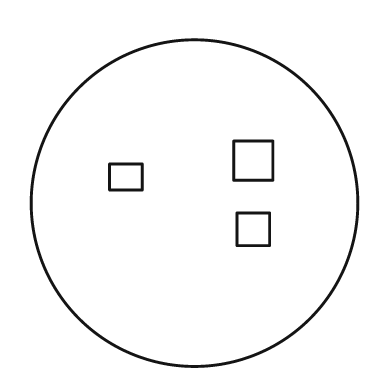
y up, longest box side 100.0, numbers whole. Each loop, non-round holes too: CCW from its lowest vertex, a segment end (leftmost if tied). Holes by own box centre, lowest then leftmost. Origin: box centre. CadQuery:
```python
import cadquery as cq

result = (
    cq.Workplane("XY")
    .moveTo(0.0, 0.0)
    .circle(50.0)
    .moveTo(13.0, -13.0)
    .lineTo(23.0, -13.0)
    .lineTo(23.0, -3.0)
    .lineTo(13.0, -3.0)
    .close()
    .moveTo(-26.0, 4.0)
    .lineTo(-16.0, 4.0)
    .lineTo(-16.0, 12.0)
    .lineTo(-26.0, 12.0)
    .close()
    .moveTo(12.0, 7.0)
    .lineTo(24.0, 7.0)
    .lineTo(24.0, 19.0)
    .lineTo(12.0, 19.0)
    .close()
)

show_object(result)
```